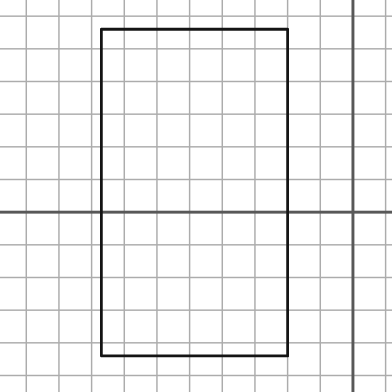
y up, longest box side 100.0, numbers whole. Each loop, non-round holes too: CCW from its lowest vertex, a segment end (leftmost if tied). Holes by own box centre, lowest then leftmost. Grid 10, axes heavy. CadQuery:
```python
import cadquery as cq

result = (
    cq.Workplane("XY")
    .moveTo(-77.0, -44.0)
    .lineTo(-20.0, -44.0)
    .lineTo(-20.0, 56.0)
    .lineTo(-77.0, 56.0)
    .close()
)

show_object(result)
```